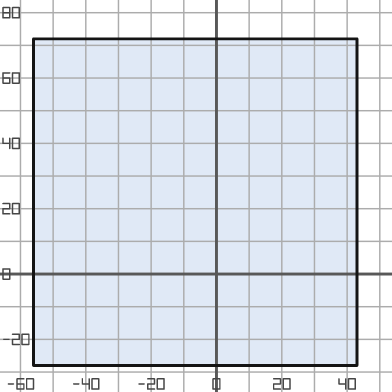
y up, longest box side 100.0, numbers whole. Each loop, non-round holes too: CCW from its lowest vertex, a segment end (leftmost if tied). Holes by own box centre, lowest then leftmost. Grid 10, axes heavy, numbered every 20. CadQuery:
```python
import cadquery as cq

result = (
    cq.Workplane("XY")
    .moveTo(-56.0, -28.0)
    .lineTo(43.0, -28.0)
    .lineTo(43.0, 72.0)
    .lineTo(-56.0, 72.0)
    .close()
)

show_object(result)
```